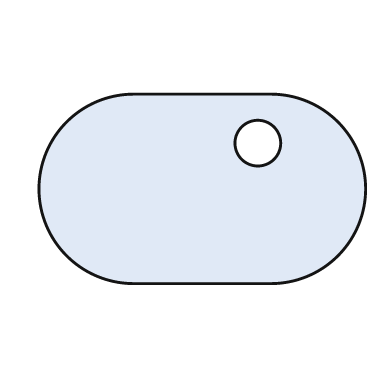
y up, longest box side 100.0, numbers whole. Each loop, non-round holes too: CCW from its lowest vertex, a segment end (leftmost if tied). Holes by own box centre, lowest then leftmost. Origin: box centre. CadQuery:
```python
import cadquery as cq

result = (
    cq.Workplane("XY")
    .moveTo(-21.0, -29.0)
    .lineTo(21.0, -29.0)
    .threePointArc((50.0, 0.0), (21.0, 29.0))
    .lineTo(-21.0, 29.0)
    .threePointArc((-50.0, 0.0), (-21.0, -29.0))
    .close()
    .moveTo(17.0, 14.0)
    .circle(7.0)
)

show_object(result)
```